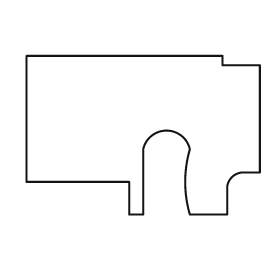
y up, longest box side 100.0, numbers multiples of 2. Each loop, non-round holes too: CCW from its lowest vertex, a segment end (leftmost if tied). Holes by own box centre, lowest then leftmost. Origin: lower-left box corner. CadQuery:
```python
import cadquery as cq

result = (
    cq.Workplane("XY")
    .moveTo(44.0, 0.0)
    .lineTo(50.0, 0.0)
    .lineTo(50.0, 28.0)
    .threePointArc((60.0, 36.0), (70.0, 28.0))
    .threePointArc((68.0, 14.0), (70.0, 0.0))
    .lineTo(86.0, 0.0)
    .lineTo(86.0, 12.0)
    .threePointArc((88.0, 16.0), (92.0, 18.0))
    .lineTo(100.0, 18.0)
    .lineTo(100.0, 64.0)
    .lineTo(84.0, 64.0)
    .lineTo(84.0, 68.0)
    .lineTo(0.0, 68.0)
    .lineTo(0.0, 14.0)
    .lineTo(44.0, 14.0)
    .close()
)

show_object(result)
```